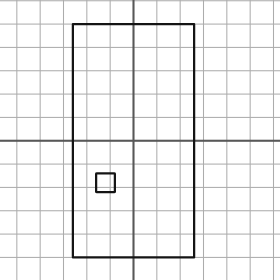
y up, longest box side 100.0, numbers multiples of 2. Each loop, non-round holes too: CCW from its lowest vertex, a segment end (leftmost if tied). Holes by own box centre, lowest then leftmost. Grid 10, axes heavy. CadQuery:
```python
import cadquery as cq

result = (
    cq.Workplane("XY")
    .moveTo(-26.0, -50.0)
    .lineTo(26.0, -50.0)
    .lineTo(26.0, 50.0)
    .lineTo(-26.0, 50.0)
    .close()
    .moveTo(-16.0, -22.0)
    .lineTo(-8.0, -22.0)
    .lineTo(-8.0, -14.0)
    .lineTo(-16.0, -14.0)
    .close()
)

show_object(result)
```